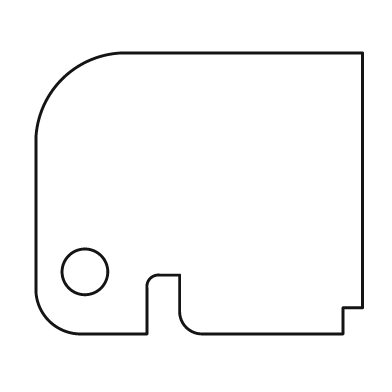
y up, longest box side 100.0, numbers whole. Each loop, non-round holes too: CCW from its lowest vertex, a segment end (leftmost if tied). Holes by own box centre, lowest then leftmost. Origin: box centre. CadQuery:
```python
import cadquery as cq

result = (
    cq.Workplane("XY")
    .moveTo(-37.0, -43.0)
    .lineTo(-16.0, -43.0)
    .lineTo(-16.0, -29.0)
    .threePointArc((-15.0, -26.0), (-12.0, -25.0))
    .lineTo(-6.0, -25.0)
    .lineTo(-6.0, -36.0)
    .threePointArc((-4.0, -41.0), (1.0, -43.0))
    .lineTo(44.0, -43.0)
    .lineTo(44.0, -35.0)
    .lineTo(50.0, -35.0)
    .lineTo(50.0, 43.0)
    .lineTo(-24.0, 43.0)
    .threePointArc((-42.0, 35.0), (-50.0, 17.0))
    .lineTo(-50.0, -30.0)
    .threePointArc((-46.0, -39.0), (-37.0, -43.0))
    .close()
    .moveTo(-35.0, -24.0)
    .circle(7.0)
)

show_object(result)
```